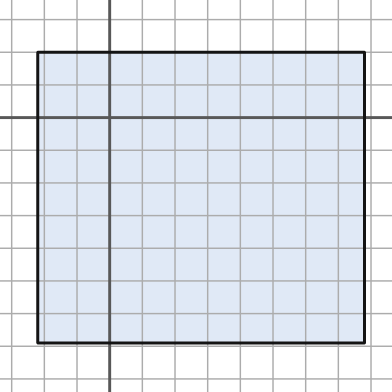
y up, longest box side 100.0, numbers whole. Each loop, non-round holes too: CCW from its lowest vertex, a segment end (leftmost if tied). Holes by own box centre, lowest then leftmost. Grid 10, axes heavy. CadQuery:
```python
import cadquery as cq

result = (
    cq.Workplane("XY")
    .moveTo(-22.0, -69.0)
    .lineTo(78.0, -69.0)
    .lineTo(78.0, 20.0)
    .lineTo(-22.0, 20.0)
    .close()
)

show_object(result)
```